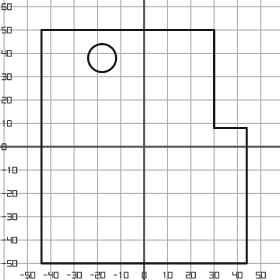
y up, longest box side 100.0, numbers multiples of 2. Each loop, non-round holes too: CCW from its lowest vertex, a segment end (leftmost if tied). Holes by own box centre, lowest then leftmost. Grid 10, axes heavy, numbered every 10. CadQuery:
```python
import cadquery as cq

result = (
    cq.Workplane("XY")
    .moveTo(-44.0, -50.0)
    .lineTo(44.0, -50.0)
    .lineTo(44.0, 8.0)
    .lineTo(30.0, 8.0)
    .lineTo(30.0, 50.0)
    .lineTo(-44.0, 50.0)
    .close()
    .moveTo(-18.0, 38.0)
    .circle(6.0)
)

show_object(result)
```